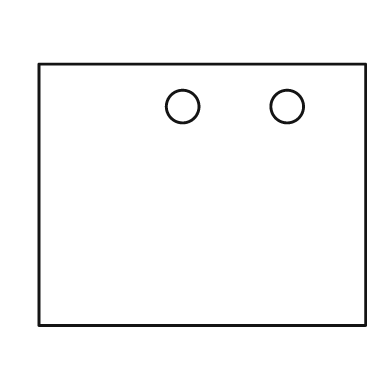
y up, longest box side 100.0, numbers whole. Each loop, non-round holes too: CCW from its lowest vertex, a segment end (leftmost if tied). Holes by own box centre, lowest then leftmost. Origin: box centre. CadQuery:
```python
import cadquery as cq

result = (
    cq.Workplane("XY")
    .moveTo(-50.0, -40.0)
    .lineTo(50.0, -40.0)
    .lineTo(50.0, 40.0)
    .lineTo(-50.0, 40.0)
    .close()
    .moveTo(-6.0, 27.0)
    .circle(5.0)
    .moveTo(26.0, 27.0)
    .circle(5.0)
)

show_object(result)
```